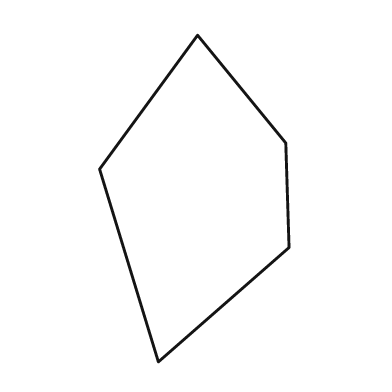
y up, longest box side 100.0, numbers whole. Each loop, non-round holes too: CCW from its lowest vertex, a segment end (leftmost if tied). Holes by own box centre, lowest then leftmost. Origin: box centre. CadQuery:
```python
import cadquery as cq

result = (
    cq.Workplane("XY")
    .moveTo(-11.0, -50.0)
    .lineTo(29.0, -15.0)
    .lineTo(28.0, 17.0)
    .lineTo(1.0, 50.0)
    .lineTo(-29.0, 9.0)
    .close()
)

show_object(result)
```